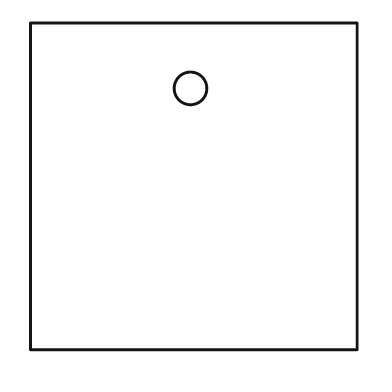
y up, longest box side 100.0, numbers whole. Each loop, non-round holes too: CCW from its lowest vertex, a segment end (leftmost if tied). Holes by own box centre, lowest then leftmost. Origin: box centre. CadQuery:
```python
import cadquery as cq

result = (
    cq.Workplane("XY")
    .moveTo(-50.0, -50.0)
    .lineTo(50.0, -50.0)
    .lineTo(50.0, 50.0)
    .lineTo(-50.0, 50.0)
    .close()
    .moveTo(-1.0, 30.0)
    .circle(5.0)
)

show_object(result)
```